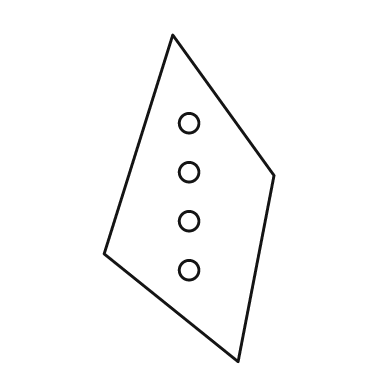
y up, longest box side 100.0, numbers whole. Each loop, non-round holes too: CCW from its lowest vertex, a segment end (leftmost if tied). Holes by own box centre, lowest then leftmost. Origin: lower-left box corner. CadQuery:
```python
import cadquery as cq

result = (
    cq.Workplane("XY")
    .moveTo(41.0, 0.0)
    .lineTo(52.0, 57.0)
    .lineTo(21.0, 100.0)
    .lineTo(0.0, 33.0)
    .close()
    .moveTo(26.0, 28.0)
    .circle(3.0)
    .moveTo(26.0, 43.0)
    .circle(3.0)
    .moveTo(26.0, 58.0)
    .circle(3.0)
    .moveTo(26.0, 73.0)
    .circle(3.0)
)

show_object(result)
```